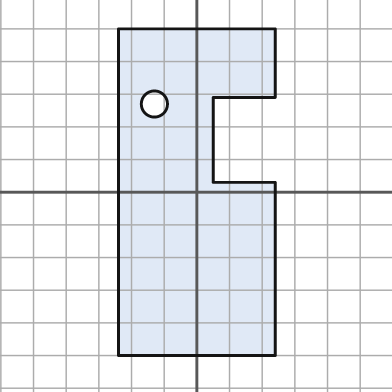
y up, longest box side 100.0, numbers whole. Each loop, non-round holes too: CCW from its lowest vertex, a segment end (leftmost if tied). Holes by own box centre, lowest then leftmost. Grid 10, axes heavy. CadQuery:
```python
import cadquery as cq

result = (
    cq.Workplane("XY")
    .moveTo(-24.0, -50.0)
    .lineTo(24.0, -50.0)
    .lineTo(24.0, 3.0)
    .lineTo(5.0, 3.0)
    .lineTo(5.0, 29.0)
    .lineTo(24.0, 29.0)
    .lineTo(24.0, 50.0)
    .lineTo(-24.0, 50.0)
    .close()
    .moveTo(-13.0, 27.0)
    .circle(4.0)
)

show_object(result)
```